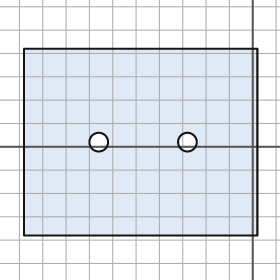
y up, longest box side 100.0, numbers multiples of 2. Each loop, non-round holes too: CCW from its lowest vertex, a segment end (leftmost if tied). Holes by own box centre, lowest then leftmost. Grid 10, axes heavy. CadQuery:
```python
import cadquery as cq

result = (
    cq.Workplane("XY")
    .moveTo(-98.0, -38.0)
    .lineTo(2.0, -38.0)
    .lineTo(2.0, 42.0)
    .lineTo(-98.0, 42.0)
    .close()
    .moveTo(-66.0, 2.0)
    .circle(4.0)
    .moveTo(-28.0, 2.0)
    .circle(4.0)
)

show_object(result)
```